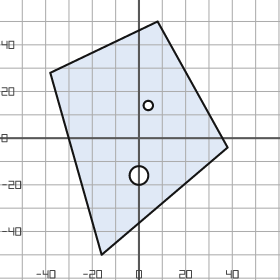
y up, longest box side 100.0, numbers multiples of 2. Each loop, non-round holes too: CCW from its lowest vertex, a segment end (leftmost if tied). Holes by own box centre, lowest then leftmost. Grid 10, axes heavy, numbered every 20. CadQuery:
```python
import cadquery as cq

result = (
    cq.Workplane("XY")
    .moveTo(-16.0, -50.0)
    .lineTo(38.0, -4.0)
    .lineTo(8.0, 50.0)
    .lineTo(-38.0, 28.0)
    .close()
    .moveTo(0.0, -16.0)
    .circle(4.0)
    .moveTo(4.0, 14.0)
    .circle(2.0)
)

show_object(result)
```